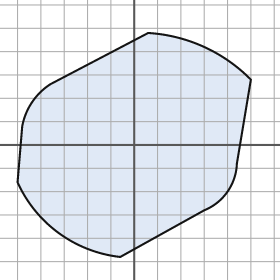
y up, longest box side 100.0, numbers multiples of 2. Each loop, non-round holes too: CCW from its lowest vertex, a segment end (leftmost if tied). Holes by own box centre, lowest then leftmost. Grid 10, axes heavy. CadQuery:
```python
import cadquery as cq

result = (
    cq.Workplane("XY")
    .moveTo(-6.0, -48.0)
    .lineTo(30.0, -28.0)
    .threePointArc((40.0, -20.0), (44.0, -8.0))
    .lineTo(50.0, 28.0)
    .threePointArc((30.0, 42.0), (6.0, 48.0))
    .lineTo(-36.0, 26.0)
    .threePointArc((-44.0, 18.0), (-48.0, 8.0))
    .lineTo(-50.0, -16.0)
    .threePointArc((-32.0, -38.0), (-6.0, -48.0))
    .close()
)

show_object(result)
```